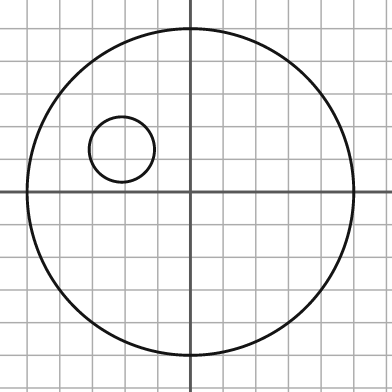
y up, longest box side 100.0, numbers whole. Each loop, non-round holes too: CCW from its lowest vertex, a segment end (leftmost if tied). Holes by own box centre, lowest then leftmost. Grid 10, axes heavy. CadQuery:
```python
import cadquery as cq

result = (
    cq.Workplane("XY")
    .moveTo(0.0, 0.0)
    .circle(50.0)
    .moveTo(-21.0, 13.0)
    .circle(10.0)
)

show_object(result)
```